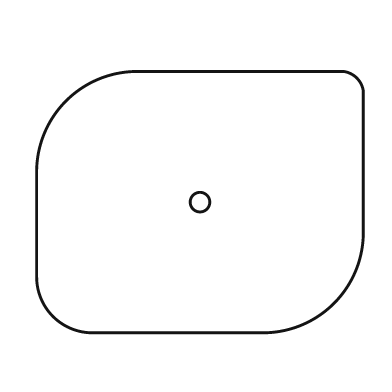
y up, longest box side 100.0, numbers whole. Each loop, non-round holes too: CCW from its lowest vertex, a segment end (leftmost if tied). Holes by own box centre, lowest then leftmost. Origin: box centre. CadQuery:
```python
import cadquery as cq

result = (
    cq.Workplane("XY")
    .moveTo(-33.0, -40.0)
    .lineTo(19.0, -40.0)
    .threePointArc((41.0, -31.0), (50.0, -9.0))
    .lineTo(50.0, 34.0)
    .threePointArc((48.0, 38.0), (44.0, 40.0))
    .lineTo(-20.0, 40.0)
    .threePointArc((-41.0, 31.0), (-50.0, 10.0))
    .lineTo(-50.0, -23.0)
    .threePointArc((-45.0, -35.0), (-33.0, -40.0))
    .close()
    .moveTo(0.0, 0.0)
    .circle(3.0)
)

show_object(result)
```